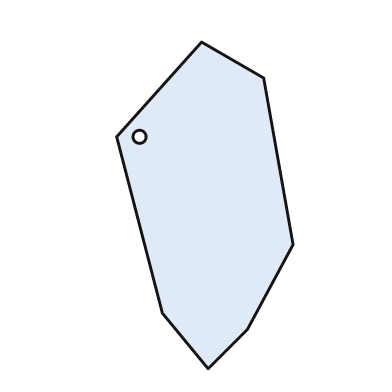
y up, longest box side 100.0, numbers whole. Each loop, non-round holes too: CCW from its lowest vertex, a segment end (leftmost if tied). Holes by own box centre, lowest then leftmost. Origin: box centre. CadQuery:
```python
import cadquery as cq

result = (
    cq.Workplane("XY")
    .moveTo(1.0, -50.0)
    .lineTo(13.0, -38.0)
    .lineTo(27.0, -12.0)
    .lineTo(18.0, 39.0)
    .lineTo(-1.0, 50.0)
    .lineTo(-27.0, 21.0)
    .lineTo(-13.0, -33.0)
    .close()
    .moveTo(-20.0, 21.0)
    .circle(2.0)
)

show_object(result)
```